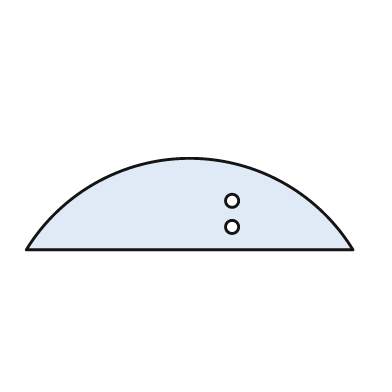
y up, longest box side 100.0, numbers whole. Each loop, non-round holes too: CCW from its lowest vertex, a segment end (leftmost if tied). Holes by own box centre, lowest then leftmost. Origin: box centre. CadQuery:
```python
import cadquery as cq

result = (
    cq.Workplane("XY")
    .moveTo(-50.0, -14.0)
    .lineTo(50.0, -14.0)
    .threePointArc((0.0, 14.0), (-50.0, -14.0))
    .close()
    .moveTo(13.0, -7.0)
    .circle(2.0)
    .moveTo(13.0, 1.0)
    .circle(2.0)
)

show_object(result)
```